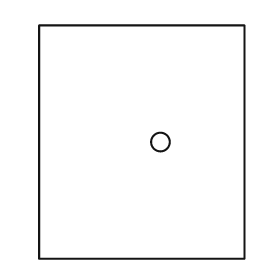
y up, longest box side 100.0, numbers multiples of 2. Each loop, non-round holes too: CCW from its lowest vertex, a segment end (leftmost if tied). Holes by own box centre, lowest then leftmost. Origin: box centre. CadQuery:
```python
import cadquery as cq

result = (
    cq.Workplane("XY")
    .moveTo(-44.0, -50.0)
    .lineTo(44.0, -50.0)
    .lineTo(44.0, 50.0)
    .lineTo(-44.0, 50.0)
    .close()
    .moveTo(8.0, 0.0)
    .circle(4.0)
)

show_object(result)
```